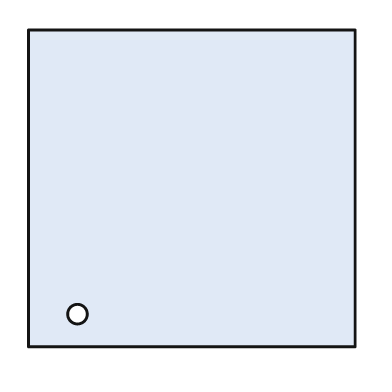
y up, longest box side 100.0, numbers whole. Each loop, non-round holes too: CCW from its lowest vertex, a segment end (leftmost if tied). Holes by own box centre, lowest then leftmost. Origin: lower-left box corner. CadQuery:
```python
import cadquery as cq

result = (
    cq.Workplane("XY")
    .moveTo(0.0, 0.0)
    .lineTo(100.0, 0.0)
    .lineTo(100.0, 97.0)
    .lineTo(0.0, 97.0)
    .close()
    .moveTo(15.0, 10.0)
    .circle(3.0)
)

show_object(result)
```